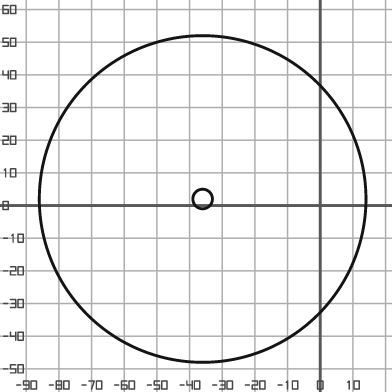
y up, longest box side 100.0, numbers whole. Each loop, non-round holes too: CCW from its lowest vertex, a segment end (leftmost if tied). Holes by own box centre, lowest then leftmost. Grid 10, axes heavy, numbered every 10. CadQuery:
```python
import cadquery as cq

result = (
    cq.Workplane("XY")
    .moveTo(-36.0, 2.0)
    .circle(50.0)
    .moveTo(-36.0, 2.0)
    .circle(3.0)
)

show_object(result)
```